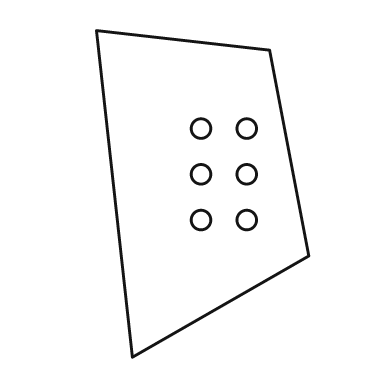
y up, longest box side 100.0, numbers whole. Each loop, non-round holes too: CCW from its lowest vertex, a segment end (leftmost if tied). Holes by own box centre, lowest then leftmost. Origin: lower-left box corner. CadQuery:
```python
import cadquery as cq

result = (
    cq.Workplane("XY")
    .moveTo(11.0, 0.0)
    .lineTo(65.0, 31.0)
    .lineTo(53.0, 94.0)
    .lineTo(0.0, 100.0)
    .close()
    .moveTo(32.0, 42.0)
    .circle(3.0)
    .moveTo(46.0, 42.0)
    .circle(3.0)
    .moveTo(32.0, 56.0)
    .circle(3.0)
    .moveTo(46.0, 56.0)
    .circle(3.0)
    .moveTo(32.0, 70.0)
    .circle(3.0)
    .moveTo(46.0, 70.0)
    .circle(3.0)
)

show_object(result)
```